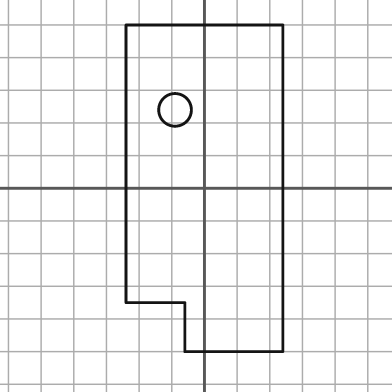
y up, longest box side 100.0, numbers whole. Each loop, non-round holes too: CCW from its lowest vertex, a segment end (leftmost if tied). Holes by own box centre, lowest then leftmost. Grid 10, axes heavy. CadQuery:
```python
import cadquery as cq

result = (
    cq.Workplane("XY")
    .moveTo(-6.0, -50.0)
    .lineTo(24.0, -50.0)
    .lineTo(24.0, 50.0)
    .lineTo(-24.0, 50.0)
    .lineTo(-24.0, -35.0)
    .lineTo(-6.0, -35.0)
    .close()
    .moveTo(-9.0, 24.0)
    .circle(5.0)
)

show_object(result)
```